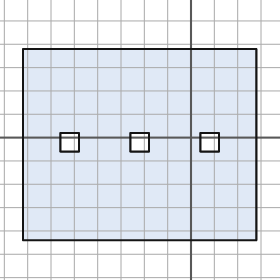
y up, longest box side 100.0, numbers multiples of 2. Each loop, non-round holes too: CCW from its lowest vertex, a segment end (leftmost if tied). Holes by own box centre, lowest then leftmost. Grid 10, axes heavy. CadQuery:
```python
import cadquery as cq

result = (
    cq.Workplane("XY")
    .moveTo(-72.0, -44.0)
    .lineTo(28.0, -44.0)
    .lineTo(28.0, 38.0)
    .lineTo(-72.0, 38.0)
    .close()
    .moveTo(-56.0, -6.0)
    .lineTo(-48.0, -6.0)
    .lineTo(-48.0, 2.0)
    .lineTo(-56.0, 2.0)
    .close()
    .moveTo(-26.0, -6.0)
    .lineTo(-18.0, -6.0)
    .lineTo(-18.0, 2.0)
    .lineTo(-26.0, 2.0)
    .close()
    .moveTo(4.0, -6.0)
    .lineTo(12.0, -6.0)
    .lineTo(12.0, 2.0)
    .lineTo(4.0, 2.0)
    .close()
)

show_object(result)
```